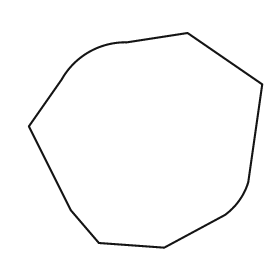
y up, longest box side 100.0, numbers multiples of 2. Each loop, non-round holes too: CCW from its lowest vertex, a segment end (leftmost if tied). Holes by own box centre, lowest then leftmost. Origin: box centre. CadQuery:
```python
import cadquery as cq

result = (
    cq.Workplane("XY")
    .moveTo(8.0, -46.0)
    .lineTo(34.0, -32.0)
    .threePointArc((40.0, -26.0), (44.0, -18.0))
    .lineTo(50.0, 24.0)
    .lineTo(18.0, 46.0)
    .lineTo(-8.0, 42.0)
    .threePointArc((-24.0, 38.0), (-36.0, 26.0))
    .lineTo(-50.0, 6.0)
    .lineTo(-32.0, -30.0)
    .lineTo(-20.0, -44.0)
    .close()
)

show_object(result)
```